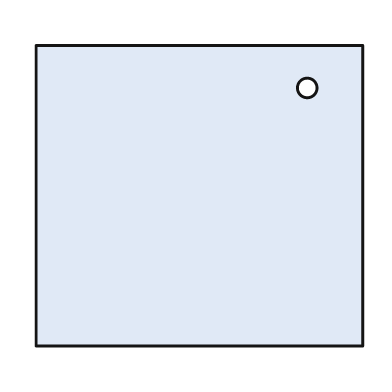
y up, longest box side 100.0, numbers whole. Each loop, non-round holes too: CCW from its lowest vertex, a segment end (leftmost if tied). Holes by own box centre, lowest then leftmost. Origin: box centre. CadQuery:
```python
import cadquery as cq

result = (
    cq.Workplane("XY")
    .moveTo(-50.0, -46.0)
    .lineTo(50.0, -46.0)
    .lineTo(50.0, 46.0)
    .lineTo(-50.0, 46.0)
    .close()
    .moveTo(33.0, 33.0)
    .circle(3.0)
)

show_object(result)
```